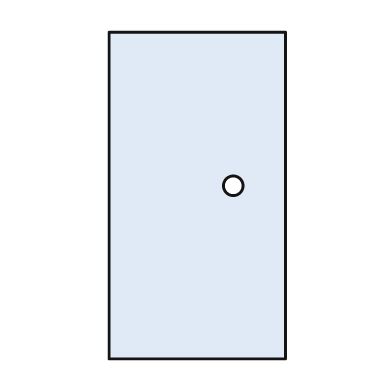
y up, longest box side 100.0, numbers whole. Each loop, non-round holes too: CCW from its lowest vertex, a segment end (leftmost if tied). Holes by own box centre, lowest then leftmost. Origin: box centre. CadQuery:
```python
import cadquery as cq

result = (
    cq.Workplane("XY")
    .moveTo(-27.0, -50.0)
    .lineTo(27.0, -50.0)
    .lineTo(27.0, 50.0)
    .lineTo(-27.0, 50.0)
    .close()
    .moveTo(11.0, 3.0)
    .circle(3.0)
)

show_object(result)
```